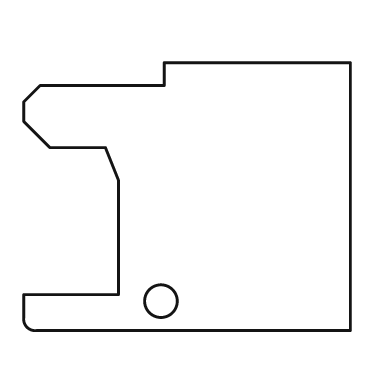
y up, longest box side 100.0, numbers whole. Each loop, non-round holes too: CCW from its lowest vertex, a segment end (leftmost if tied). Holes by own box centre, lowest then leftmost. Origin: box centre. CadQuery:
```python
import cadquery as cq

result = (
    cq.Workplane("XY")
    .moveTo(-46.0, -41.0)
    .lineTo(50.0, -41.0)
    .lineTo(50.0, 41.0)
    .lineTo(-7.0, 41.0)
    .lineTo(-7.0, 34.0)
    .lineTo(-45.0, 34.0)
    .lineTo(-50.0, 29.0)
    .lineTo(-50.0, 23.0)
    .lineTo(-42.0, 15.0)
    .lineTo(-25.0, 15.0)
    .lineTo(-21.0, 5.0)
    .lineTo(-21.0, -30.0)
    .lineTo(-50.0, -30.0)
    .lineTo(-50.0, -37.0)
    .threePointArc((-49.0, -40.0), (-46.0, -41.0))
    .close()
    .moveTo(-8.0, -32.0)
    .circle(5.0)
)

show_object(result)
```